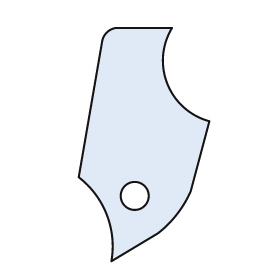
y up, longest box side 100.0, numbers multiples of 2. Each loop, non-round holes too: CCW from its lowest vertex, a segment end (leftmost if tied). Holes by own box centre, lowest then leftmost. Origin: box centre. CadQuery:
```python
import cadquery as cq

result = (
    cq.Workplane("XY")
    .moveTo(-14.0, -50.0)
    .lineTo(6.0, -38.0)
    .threePointArc((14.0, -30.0), (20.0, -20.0))
    .lineTo(28.0, 10.0)
    .threePointArc((10.0, 26.0), (12.0, 50.0))
    .lineTo(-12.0, 50.0)
    .threePointArc((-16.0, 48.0), (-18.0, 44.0))
    .lineTo(-28.0, -14.0)
    .threePointArc((-16.0, -30.0), (-14.0, -50.0))
    .close()
    .moveTo(-4.0, -22.0)
    .circle(6.0)
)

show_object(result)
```